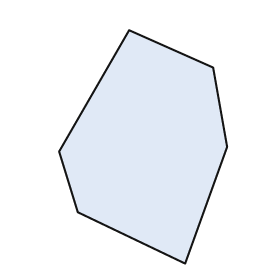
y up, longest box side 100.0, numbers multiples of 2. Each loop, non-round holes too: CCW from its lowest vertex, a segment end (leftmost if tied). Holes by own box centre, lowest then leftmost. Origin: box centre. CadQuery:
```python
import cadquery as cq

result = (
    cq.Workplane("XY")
    .moveTo(18.0, -50.0)
    .lineTo(36.0, 0.0)
    .lineTo(30.0, 34.0)
    .lineTo(-6.0, 50.0)
    .lineTo(-36.0, -2.0)
    .lineTo(-28.0, -28.0)
    .close()
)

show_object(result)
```